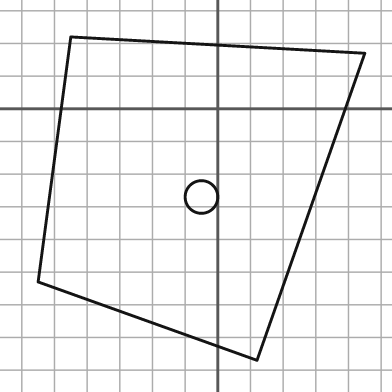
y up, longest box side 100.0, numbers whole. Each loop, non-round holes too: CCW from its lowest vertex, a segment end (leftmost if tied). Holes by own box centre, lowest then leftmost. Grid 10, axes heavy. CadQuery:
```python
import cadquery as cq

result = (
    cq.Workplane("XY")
    .moveTo(12.0, -77.0)
    .lineTo(45.0, 17.0)
    .lineTo(-45.0, 22.0)
    .lineTo(-55.0, -53.0)
    .close()
    .moveTo(-5.0, -27.0)
    .circle(5.0)
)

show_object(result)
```